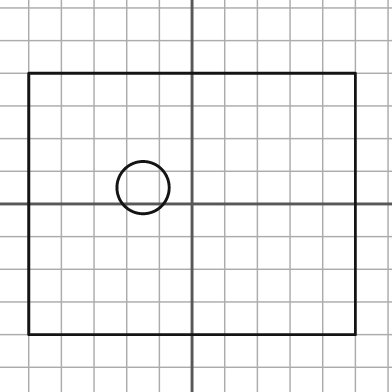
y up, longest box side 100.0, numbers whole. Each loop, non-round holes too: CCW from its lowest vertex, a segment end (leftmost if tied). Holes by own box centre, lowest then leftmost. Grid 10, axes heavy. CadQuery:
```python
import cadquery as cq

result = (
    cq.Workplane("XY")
    .moveTo(-50.0, -40.0)
    .lineTo(50.0, -40.0)
    .lineTo(50.0, 40.0)
    .lineTo(-50.0, 40.0)
    .close()
    .moveTo(-15.0, 5.0)
    .circle(8.0)
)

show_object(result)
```